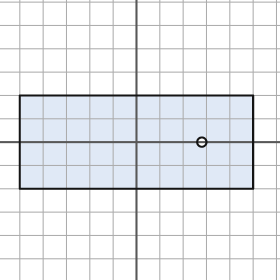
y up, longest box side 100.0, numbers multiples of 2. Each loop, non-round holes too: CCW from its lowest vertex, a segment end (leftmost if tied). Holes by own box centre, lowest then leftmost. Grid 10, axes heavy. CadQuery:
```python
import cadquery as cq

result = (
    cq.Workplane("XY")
    .moveTo(-50.0, -20.0)
    .lineTo(50.0, -20.0)
    .lineTo(50.0, 20.0)
    .lineTo(-50.0, 20.0)
    .close()
    .moveTo(28.0, 0.0)
    .circle(2.0)
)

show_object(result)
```